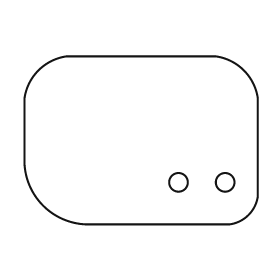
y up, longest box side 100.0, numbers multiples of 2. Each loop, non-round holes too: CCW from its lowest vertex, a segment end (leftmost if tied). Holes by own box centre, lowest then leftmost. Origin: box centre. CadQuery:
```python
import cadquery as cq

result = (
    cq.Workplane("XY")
    .moveTo(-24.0, -36.0)
    .lineTo(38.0, -36.0)
    .threePointArc((46.0, -32.0), (50.0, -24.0))
    .lineTo(50.0, 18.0)
    .threePointArc((44.0, 30.0), (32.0, 36.0))
    .lineTo(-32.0, 36.0)
    .threePointArc((-44.0, 30.0), (-50.0, 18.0))
    .lineTo(-50.0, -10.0)
    .threePointArc((-42.0, -28.0), (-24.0, -36.0))
    .close()
    .moveTo(16.0, -18.0)
    .circle(4.0)
    .moveTo(36.0, -18.0)
    .circle(4.0)
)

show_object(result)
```